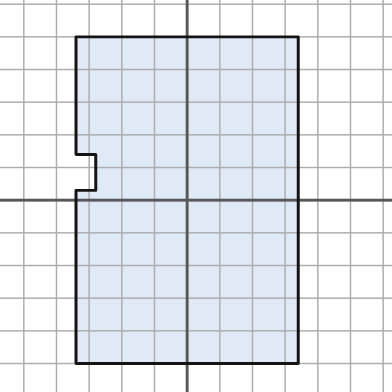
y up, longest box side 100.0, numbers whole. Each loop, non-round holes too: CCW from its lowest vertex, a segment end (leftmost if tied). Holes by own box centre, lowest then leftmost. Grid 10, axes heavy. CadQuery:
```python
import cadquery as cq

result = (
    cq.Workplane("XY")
    .moveTo(-34.0, -50.0)
    .lineTo(34.0, -50.0)
    .lineTo(34.0, 50.0)
    .lineTo(-34.0, 50.0)
    .lineTo(-34.0, 14.0)
    .lineTo(-28.0, 14.0)
    .lineTo(-28.0, 3.0)
    .lineTo(-34.0, 3.0)
    .close()
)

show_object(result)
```